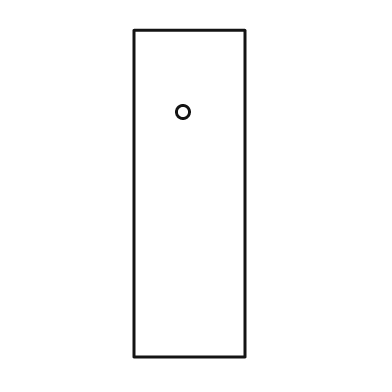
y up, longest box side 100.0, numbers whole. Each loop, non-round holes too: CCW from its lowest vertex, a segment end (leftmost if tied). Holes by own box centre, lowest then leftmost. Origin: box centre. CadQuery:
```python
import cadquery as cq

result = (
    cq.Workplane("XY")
    .moveTo(-17.0, -50.0)
    .lineTo(17.0, -50.0)
    .lineTo(17.0, 50.0)
    .lineTo(-17.0, 50.0)
    .close()
    .moveTo(-2.0, 25.0)
    .circle(2.0)
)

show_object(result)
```